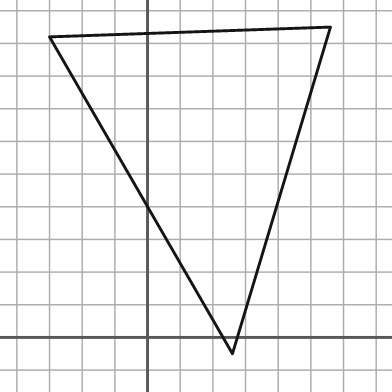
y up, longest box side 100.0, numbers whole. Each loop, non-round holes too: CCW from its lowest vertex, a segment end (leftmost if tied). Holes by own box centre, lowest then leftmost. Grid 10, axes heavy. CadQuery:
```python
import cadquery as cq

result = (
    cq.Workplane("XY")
    .moveTo(26.0, -5.0)
    .lineTo(56.0, 95.0)
    .lineTo(-30.0, 92.0)
    .close()
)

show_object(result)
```